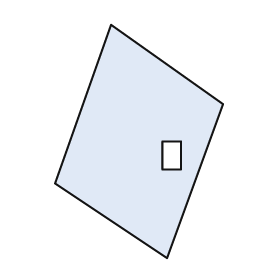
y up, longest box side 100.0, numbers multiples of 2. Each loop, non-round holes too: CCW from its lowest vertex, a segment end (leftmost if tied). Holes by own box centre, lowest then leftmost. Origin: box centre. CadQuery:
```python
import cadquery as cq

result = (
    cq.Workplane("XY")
    .moveTo(12.0, -50.0)
    .lineTo(36.0, 16.0)
    .lineTo(-12.0, 50.0)
    .lineTo(-36.0, -18.0)
    .close()
    .moveTo(10.0, -12.0)
    .lineTo(18.0, -12.0)
    .lineTo(18.0, 0.0)
    .lineTo(10.0, 0.0)
    .close()
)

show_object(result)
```